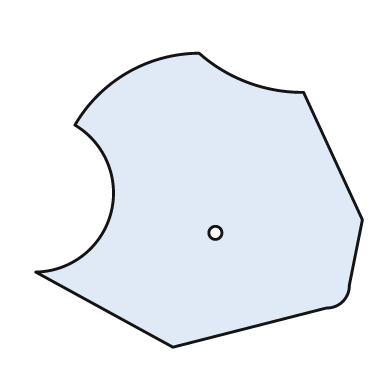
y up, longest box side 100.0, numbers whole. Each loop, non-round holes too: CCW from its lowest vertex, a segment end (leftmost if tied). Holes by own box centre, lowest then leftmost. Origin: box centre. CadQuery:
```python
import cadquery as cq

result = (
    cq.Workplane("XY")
    .moveTo(-8.0, -45.0)
    .lineTo(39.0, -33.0)
    .threePointArc((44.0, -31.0), (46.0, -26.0))
    .lineTo(50.0, -6.0)
    .lineTo(32.0, 33.0)
    .threePointArc((15.0, 36.0), (0.0, 45.0))
    .threePointArc((-22.0, 39.0), (-38.0, 23.0))
    .threePointArc((-27.0, -4.0), (-50.0, -22.0))
    .close()
    .moveTo(5.0, -10.0)
    .circle(2.0)
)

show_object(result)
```